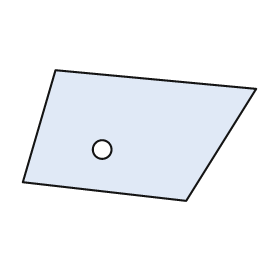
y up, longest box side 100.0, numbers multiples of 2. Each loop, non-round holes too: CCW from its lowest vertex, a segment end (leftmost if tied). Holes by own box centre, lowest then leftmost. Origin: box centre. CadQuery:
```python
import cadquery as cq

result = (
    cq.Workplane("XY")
    .moveTo(20.0, -28.0)
    .lineTo(50.0, 20.0)
    .lineTo(-36.0, 28.0)
    .lineTo(-50.0, -20.0)
    .close()
    .moveTo(-16.0, -6.0)
    .circle(4.0)
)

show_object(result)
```